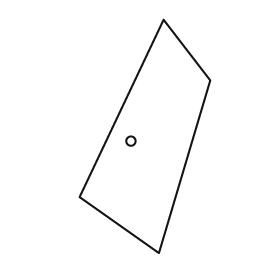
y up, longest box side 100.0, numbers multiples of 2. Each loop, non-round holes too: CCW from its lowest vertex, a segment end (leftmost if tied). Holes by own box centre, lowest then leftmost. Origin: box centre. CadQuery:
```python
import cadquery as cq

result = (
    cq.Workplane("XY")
    .moveTo(6.0, -50.0)
    .lineTo(28.0, 24.0)
    .lineTo(8.0, 50.0)
    .lineTo(-28.0, -26.0)
    .close()
    .moveTo(-6.0, -2.0)
    .circle(2.0)
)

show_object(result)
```